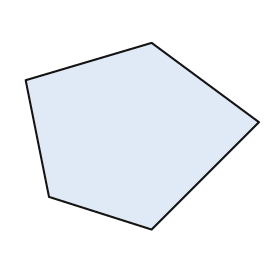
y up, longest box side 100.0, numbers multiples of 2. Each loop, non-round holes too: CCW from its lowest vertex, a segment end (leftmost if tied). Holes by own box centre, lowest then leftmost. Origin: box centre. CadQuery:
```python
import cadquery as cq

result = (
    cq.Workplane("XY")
    .moveTo(4.0, -40.0)
    .lineTo(50.0, 6.0)
    .lineTo(4.0, 40.0)
    .lineTo(-50.0, 24.0)
    .lineTo(-40.0, -26.0)
    .close()
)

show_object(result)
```